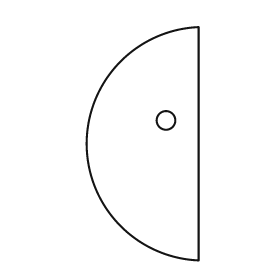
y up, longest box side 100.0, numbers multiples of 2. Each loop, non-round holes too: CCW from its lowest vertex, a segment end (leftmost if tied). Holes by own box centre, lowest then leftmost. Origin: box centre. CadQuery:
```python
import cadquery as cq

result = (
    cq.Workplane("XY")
    .moveTo(24.0, -50.0)
    .lineTo(24.0, 50.0)
    .threePointArc((-24.0, 0.0), (24.0, -50.0))
    .close()
    .moveTo(10.0, 10.0)
    .circle(4.0)
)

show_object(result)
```